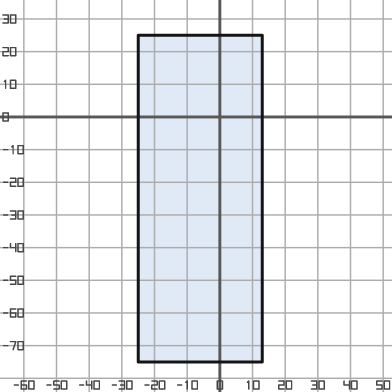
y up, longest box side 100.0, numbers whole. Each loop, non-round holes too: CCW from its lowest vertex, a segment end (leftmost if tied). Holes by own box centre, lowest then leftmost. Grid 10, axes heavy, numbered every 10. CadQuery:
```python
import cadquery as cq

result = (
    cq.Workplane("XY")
    .moveTo(-25.0, -75.0)
    .lineTo(13.0, -75.0)
    .lineTo(13.0, 25.0)
    .lineTo(-25.0, 25.0)
    .close()
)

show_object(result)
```